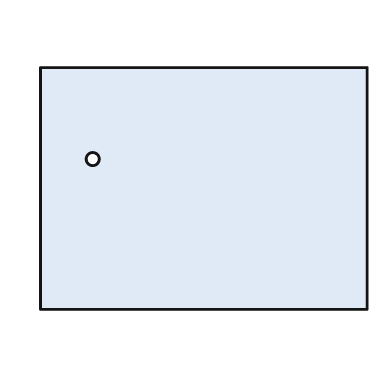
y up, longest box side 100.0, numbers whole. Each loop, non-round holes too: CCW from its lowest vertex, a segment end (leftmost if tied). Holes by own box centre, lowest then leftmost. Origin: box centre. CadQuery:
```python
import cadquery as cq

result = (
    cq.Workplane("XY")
    .moveTo(-50.0, -37.0)
    .lineTo(50.0, -37.0)
    .lineTo(50.0, 37.0)
    .lineTo(-50.0, 37.0)
    .close()
    .moveTo(-34.0, 9.0)
    .circle(2.0)
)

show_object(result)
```